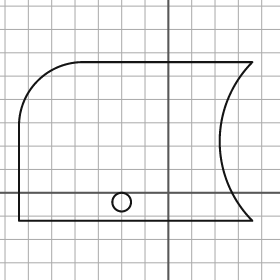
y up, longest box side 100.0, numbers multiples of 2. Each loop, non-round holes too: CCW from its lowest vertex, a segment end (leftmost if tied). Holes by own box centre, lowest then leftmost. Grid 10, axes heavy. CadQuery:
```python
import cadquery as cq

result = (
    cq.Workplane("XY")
    .moveTo(-64.0, -12.0)
    .lineTo(36.0, -12.0)
    .threePointArc((22.0, 22.0), (36.0, 56.0))
    .lineTo(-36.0, 56.0)
    .threePointArc((-56.0, 48.0), (-64.0, 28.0))
    .close()
    .moveTo(-20.0, -4.0)
    .circle(4.0)
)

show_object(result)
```